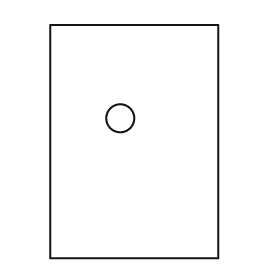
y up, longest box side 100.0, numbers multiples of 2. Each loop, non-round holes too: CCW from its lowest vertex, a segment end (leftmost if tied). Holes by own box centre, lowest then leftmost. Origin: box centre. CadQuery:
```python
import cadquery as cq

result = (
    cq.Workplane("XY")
    .moveTo(-36.0, -50.0)
    .lineTo(36.0, -50.0)
    .lineTo(36.0, 50.0)
    .lineTo(-36.0, 50.0)
    .close()
    .moveTo(-6.0, 10.0)
    .circle(6.0)
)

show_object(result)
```